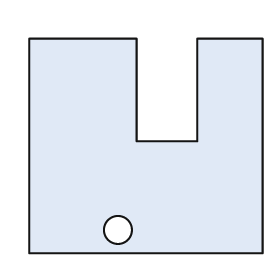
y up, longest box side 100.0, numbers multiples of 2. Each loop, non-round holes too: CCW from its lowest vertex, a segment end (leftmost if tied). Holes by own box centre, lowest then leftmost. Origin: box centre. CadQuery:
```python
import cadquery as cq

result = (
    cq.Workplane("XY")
    .moveTo(-50.0, -46.0)
    .lineTo(50.0, -46.0)
    .lineTo(50.0, 46.0)
    .lineTo(22.0, 46.0)
    .lineTo(22.0, 2.0)
    .lineTo(-4.0, 2.0)
    .lineTo(-4.0, 46.0)
    .lineTo(-50.0, 46.0)
    .close()
    .moveTo(-12.0, -36.0)
    .circle(6.0)
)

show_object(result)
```